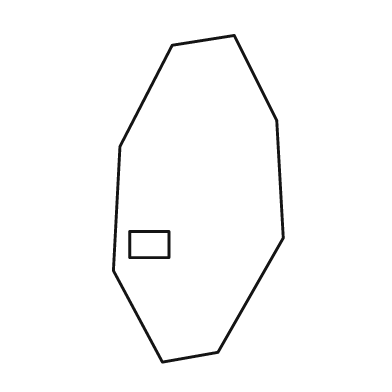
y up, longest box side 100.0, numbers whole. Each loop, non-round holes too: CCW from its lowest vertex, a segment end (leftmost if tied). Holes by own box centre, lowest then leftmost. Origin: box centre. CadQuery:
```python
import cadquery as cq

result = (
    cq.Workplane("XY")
    .moveTo(-11.0, -50.0)
    .lineTo(6.0, -47.0)
    .lineTo(26.0, -12.0)
    .lineTo(24.0, 24.0)
    .lineTo(11.0, 50.0)
    .lineTo(-8.0, 47.0)
    .lineTo(-24.0, 16.0)
    .lineTo(-26.0, -22.0)
    .close()
    .moveTo(-21.0, -18.0)
    .lineTo(-9.0, -18.0)
    .lineTo(-9.0, -10.0)
    .lineTo(-21.0, -10.0)
    .close()
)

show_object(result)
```